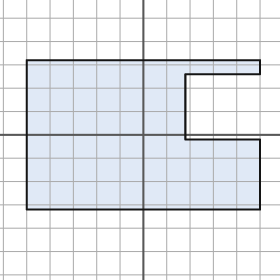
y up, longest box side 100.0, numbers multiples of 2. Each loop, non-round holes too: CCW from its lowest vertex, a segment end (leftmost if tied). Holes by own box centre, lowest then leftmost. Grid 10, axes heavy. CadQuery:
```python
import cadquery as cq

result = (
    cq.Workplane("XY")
    .moveTo(-50.0, -32.0)
    .lineTo(50.0, -32.0)
    .lineTo(50.0, -2.0)
    .lineTo(18.0, -2.0)
    .lineTo(18.0, 26.0)
    .lineTo(50.0, 26.0)
    .lineTo(50.0, 32.0)
    .lineTo(-50.0, 32.0)
    .close()
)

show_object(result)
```